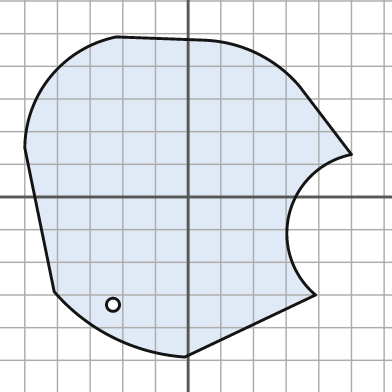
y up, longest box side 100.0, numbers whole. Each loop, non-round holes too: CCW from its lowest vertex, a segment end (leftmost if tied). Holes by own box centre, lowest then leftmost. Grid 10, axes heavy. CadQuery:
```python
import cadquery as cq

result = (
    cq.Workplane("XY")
    .moveTo(-1.0, -49.0)
    .lineTo(39.0, -30.0)
    .threePointArc((31.0, -5.0), (50.0, 13.0))
    .lineTo(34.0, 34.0)
    .threePointArc((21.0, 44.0), (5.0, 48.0))
    .lineTo(-22.0, 49.0)
    .threePointArc((-42.0, 37.0), (-50.0, 15.0))
    .lineTo(-41.0, -29.0)
    .threePointArc((-23.0, -43.0), (-1.0, -49.0))
    .close()
    .moveTo(-23.0, -33.0)
    .circle(2.0)
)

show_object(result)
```